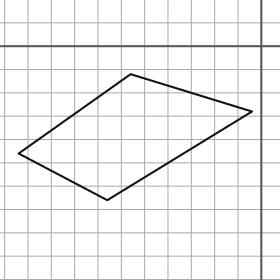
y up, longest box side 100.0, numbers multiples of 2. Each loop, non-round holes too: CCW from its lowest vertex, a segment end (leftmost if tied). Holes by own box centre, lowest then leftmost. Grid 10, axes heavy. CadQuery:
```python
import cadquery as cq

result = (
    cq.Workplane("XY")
    .moveTo(-66.0, -66.0)
    .lineTo(-4.0, -28.0)
    .lineTo(-56.0, -12.0)
    .lineTo(-104.0, -46.0)
    .close()
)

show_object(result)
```